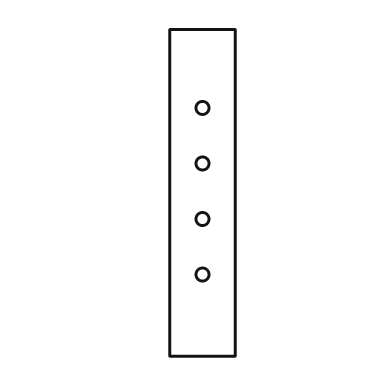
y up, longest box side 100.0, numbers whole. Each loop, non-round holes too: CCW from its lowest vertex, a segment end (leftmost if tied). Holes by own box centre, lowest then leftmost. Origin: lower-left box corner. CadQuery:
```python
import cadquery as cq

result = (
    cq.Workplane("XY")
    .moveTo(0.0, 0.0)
    .lineTo(20.0, 0.0)
    .lineTo(20.0, 100.0)
    .lineTo(0.0, 100.0)
    .close()
    .moveTo(10.0, 25.0)
    .circle(2.0)
    .moveTo(10.0, 42.0)
    .circle(2.0)
    .moveTo(10.0, 59.0)
    .circle(2.0)
    .moveTo(10.0, 76.0)
    .circle(2.0)
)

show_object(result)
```